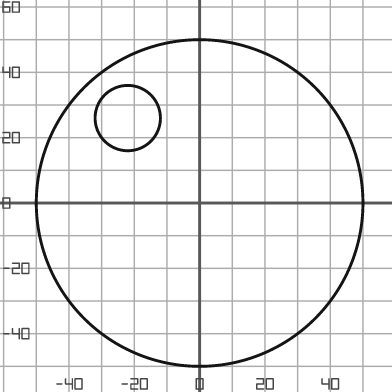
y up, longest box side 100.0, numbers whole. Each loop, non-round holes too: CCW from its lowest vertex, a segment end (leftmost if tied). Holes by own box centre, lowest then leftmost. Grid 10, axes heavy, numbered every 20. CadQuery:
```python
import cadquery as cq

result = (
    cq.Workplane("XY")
    .moveTo(0.0, 0.0)
    .circle(50.0)
    .moveTo(-22.0, 26.0)
    .circle(10.0)
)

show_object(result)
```